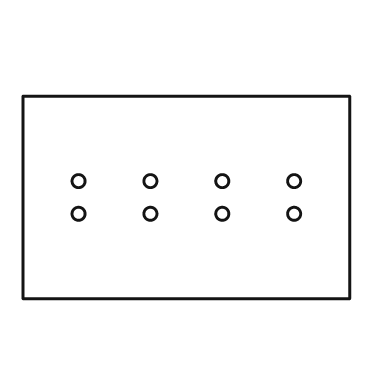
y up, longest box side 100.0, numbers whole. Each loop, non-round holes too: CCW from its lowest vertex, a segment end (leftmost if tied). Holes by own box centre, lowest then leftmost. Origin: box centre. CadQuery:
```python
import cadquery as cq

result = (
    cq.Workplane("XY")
    .moveTo(-50.0, -31.0)
    .lineTo(50.0, -31.0)
    .lineTo(50.0, 31.0)
    .lineTo(-50.0, 31.0)
    .close()
    .moveTo(-33.0, -5.0)
    .circle(2.0)
    .moveTo(-11.0, -5.0)
    .circle(2.0)
    .moveTo(11.0, -5.0)
    .circle(2.0)
    .moveTo(33.0, -5.0)
    .circle(2.0)
    .moveTo(-33.0, 5.0)
    .circle(2.0)
    .moveTo(-11.0, 5.0)
    .circle(2.0)
    .moveTo(11.0, 5.0)
    .circle(2.0)
    .moveTo(33.0, 5.0)
    .circle(2.0)
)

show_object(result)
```